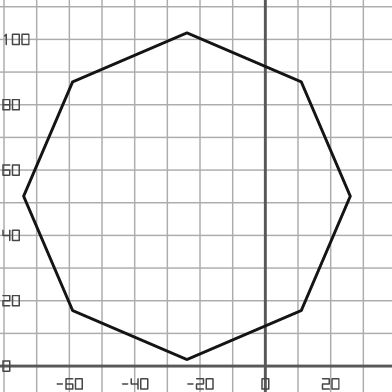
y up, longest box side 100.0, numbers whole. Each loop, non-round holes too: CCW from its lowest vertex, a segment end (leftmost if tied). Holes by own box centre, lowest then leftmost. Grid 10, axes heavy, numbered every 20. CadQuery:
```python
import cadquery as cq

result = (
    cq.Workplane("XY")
    .moveTo(-24.0, 2.0)
    .lineTo(11.0, 17.0)
    .lineTo(26.0, 52.0)
    .lineTo(11.0, 87.0)
    .lineTo(-24.0, 102.0)
    .lineTo(-59.0, 87.0)
    .lineTo(-74.0, 52.0)
    .lineTo(-59.0, 17.0)
    .close()
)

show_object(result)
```